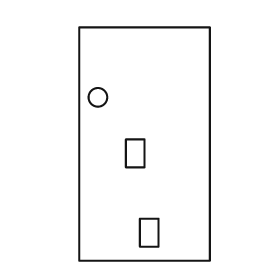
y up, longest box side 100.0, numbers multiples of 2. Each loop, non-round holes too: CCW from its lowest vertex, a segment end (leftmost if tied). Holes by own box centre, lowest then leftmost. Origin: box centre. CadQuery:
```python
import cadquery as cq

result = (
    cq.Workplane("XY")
    .moveTo(-28.0, -50.0)
    .lineTo(28.0, -50.0)
    .lineTo(28.0, 50.0)
    .lineTo(-28.0, 50.0)
    .close()
    .moveTo(-2.0, -44.0)
    .lineTo(6.0, -44.0)
    .lineTo(6.0, -32.0)
    .lineTo(-2.0, -32.0)
    .close()
    .moveTo(-8.0, -10.0)
    .lineTo(0.0, -10.0)
    .lineTo(0.0, 2.0)
    .lineTo(-8.0, 2.0)
    .close()
    .moveTo(-20.0, 20.0)
    .circle(4.0)
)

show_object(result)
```